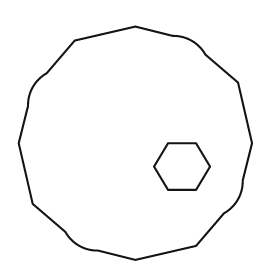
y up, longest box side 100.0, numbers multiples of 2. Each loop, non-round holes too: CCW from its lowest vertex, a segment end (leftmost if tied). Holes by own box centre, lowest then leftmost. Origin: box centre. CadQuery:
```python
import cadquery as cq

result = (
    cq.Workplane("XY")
    .moveTo(0.0, -50.0)
    .lineTo(26.0, -44.0)
    .lineTo(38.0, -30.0)
    .threePointArc((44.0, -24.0), (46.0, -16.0))
    .lineTo(50.0, 0.0)
    .lineTo(44.0, 26.0)
    .lineTo(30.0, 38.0)
    .threePointArc((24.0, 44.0), (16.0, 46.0))
    .lineTo(0.0, 50.0)
    .lineTo(-26.0, 44.0)
    .lineTo(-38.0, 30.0)
    .threePointArc((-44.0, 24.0), (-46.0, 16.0))
    .lineTo(-50.0, 0.0)
    .lineTo(-44.0, -26.0)
    .lineTo(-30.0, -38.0)
    .threePointArc((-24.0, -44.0), (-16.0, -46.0))
    .close()
    .moveTo(14.0, -20.0)
    .lineTo(26.0, -20.0)
    .lineTo(32.0, -10.0)
    .lineTo(26.0, 0.0)
    .lineTo(14.0, 0.0)
    .lineTo(8.0, -10.0)
    .close()
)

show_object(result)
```